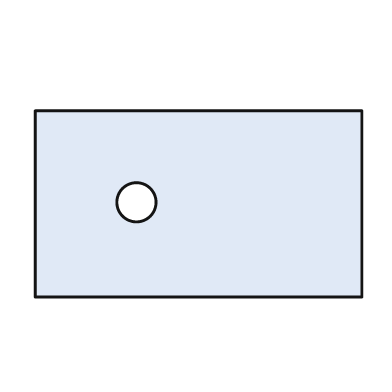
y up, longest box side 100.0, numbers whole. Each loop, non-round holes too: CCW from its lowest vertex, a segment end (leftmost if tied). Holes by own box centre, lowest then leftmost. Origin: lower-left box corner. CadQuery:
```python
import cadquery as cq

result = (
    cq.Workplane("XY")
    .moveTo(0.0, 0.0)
    .lineTo(100.0, 0.0)
    .lineTo(100.0, 57.0)
    .lineTo(0.0, 57.0)
    .close()
    .moveTo(31.0, 29.0)
    .circle(6.0)
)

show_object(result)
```